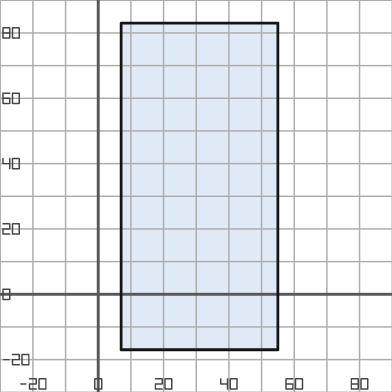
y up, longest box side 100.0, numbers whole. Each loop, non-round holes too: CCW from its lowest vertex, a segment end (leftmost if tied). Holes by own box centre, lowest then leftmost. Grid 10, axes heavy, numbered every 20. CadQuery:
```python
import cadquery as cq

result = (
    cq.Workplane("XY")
    .moveTo(7.0, -17.0)
    .lineTo(55.0, -17.0)
    .lineTo(55.0, 83.0)
    .lineTo(7.0, 83.0)
    .close()
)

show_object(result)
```